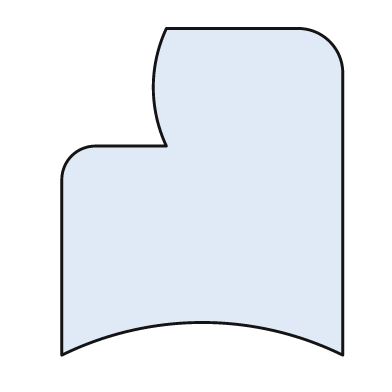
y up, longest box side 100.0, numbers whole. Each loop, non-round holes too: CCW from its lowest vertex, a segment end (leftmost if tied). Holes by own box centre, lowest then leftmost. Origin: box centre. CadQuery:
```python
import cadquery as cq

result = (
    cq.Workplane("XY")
    .moveTo(-43.0, -50.0)
    .threePointArc((0.0, -40.0), (43.0, -50.0))
    .lineTo(43.0, 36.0)
    .threePointArc((39.0, 46.0), (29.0, 50.0))
    .lineTo(-11.0, 50.0)
    .threePointArc((-15.0, 32.0), (-11.0, 14.0))
    .lineTo(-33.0, 14.0)
    .threePointArc((-40.0, 11.0), (-43.0, 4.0))
    .close()
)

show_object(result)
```